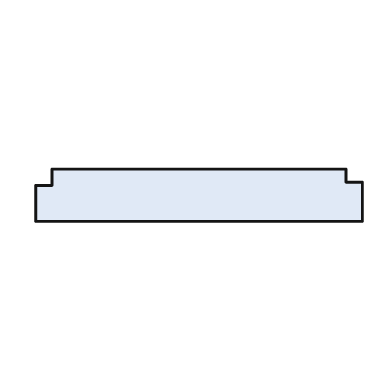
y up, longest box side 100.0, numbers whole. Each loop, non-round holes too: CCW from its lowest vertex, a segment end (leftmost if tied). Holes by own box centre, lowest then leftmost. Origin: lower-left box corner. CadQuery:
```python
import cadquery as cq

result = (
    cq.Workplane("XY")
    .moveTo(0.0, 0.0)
    .lineTo(100.0, 0.0)
    .lineTo(100.0, 12.0)
    .lineTo(95.0, 12.0)
    .lineTo(95.0, 16.0)
    .lineTo(5.0, 16.0)
    .lineTo(5.0, 11.0)
    .lineTo(0.0, 11.0)
    .close()
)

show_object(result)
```